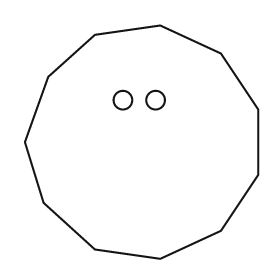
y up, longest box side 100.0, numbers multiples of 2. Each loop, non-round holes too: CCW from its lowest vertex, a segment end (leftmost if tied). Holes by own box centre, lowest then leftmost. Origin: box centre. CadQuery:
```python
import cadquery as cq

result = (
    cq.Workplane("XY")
    .moveTo(8.0, -50.0)
    .lineTo(34.0, -38.0)
    .lineTo(50.0, -14.0)
    .lineTo(50.0, 14.0)
    .lineTo(34.0, 38.0)
    .lineTo(8.0, 50.0)
    .lineTo(-20.0, 46.0)
    .lineTo(-40.0, 28.0)
    .lineTo(-50.0, 0.0)
    .lineTo(-42.0, -26.0)
    .lineTo(-20.0, -46.0)
    .close()
    .moveTo(-8.0, 18.0)
    .circle(4.0)
    .moveTo(6.0, 18.0)
    .circle(4.0)
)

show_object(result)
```